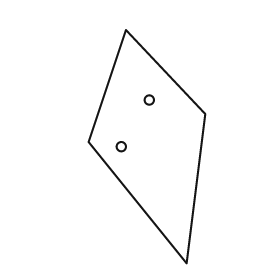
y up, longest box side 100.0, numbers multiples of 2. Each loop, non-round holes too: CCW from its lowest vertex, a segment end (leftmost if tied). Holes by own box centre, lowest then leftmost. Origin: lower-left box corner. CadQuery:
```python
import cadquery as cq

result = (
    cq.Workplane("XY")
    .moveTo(42.0, 0.0)
    .lineTo(50.0, 64.0)
    .lineTo(16.0, 100.0)
    .lineTo(0.0, 52.0)
    .close()
    .moveTo(14.0, 50.0)
    .circle(2.0)
    .moveTo(26.0, 70.0)
    .circle(2.0)
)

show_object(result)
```